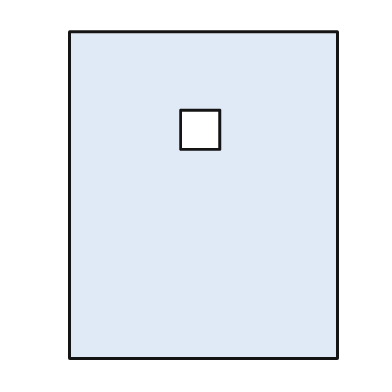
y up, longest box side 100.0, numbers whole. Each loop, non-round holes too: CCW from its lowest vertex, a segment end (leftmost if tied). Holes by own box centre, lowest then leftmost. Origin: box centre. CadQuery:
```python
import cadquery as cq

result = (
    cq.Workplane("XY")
    .moveTo(-41.0, -50.0)
    .lineTo(41.0, -50.0)
    .lineTo(41.0, 50.0)
    .lineTo(-41.0, 50.0)
    .close()
    .moveTo(-7.0, 14.0)
    .lineTo(5.0, 14.0)
    .lineTo(5.0, 26.0)
    .lineTo(-7.0, 26.0)
    .close()
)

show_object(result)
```